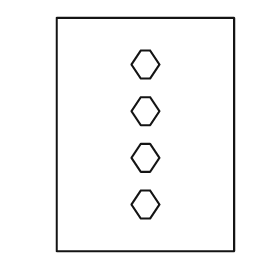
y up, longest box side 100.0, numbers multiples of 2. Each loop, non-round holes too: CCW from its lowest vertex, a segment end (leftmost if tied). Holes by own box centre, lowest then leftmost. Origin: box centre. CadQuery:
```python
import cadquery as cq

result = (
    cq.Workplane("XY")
    .moveTo(-38.0, -50.0)
    .lineTo(38.0, -50.0)
    .lineTo(38.0, 50.0)
    .lineTo(-38.0, 50.0)
    .close()
    .moveTo(-2.0, -36.0)
    .lineTo(2.0, -36.0)
    .lineTo(6.0, -30.0)
    .lineTo(2.0, -24.0)
    .lineTo(-2.0, -24.0)
    .lineTo(-6.0, -30.0)
    .close()
    .moveTo(-2.0, -16.0)
    .lineTo(2.0, -16.0)
    .lineTo(6.0, -10.0)
    .lineTo(2.0, -4.0)
    .lineTo(-2.0, -4.0)
    .lineTo(-6.0, -10.0)
    .close()
    .moveTo(-2.0, 4.0)
    .lineTo(2.0, 4.0)
    .lineTo(6.0, 10.0)
    .lineTo(2.0, 16.0)
    .lineTo(-2.0, 16.0)
    .lineTo(-6.0, 10.0)
    .close()
    .moveTo(-2.0, 24.0)
    .lineTo(2.0, 24.0)
    .lineTo(6.0, 30.0)
    .lineTo(2.0, 36.0)
    .lineTo(-2.0, 36.0)
    .lineTo(-6.0, 30.0)
    .close()
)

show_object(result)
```